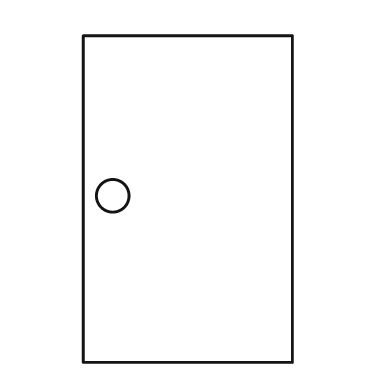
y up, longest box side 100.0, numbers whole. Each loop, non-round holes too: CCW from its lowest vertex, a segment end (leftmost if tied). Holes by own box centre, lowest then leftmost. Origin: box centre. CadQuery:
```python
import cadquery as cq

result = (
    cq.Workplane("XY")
    .moveTo(-32.0, -50.0)
    .lineTo(32.0, -50.0)
    .lineTo(32.0, 50.0)
    .lineTo(-32.0, 50.0)
    .close()
    .moveTo(-23.0, 1.0)
    .circle(5.0)
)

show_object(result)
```